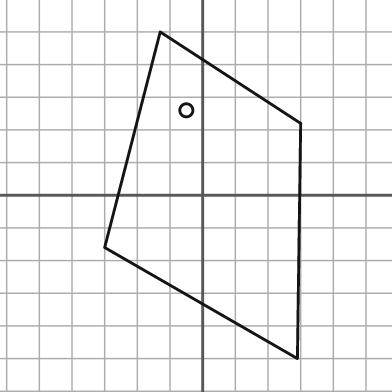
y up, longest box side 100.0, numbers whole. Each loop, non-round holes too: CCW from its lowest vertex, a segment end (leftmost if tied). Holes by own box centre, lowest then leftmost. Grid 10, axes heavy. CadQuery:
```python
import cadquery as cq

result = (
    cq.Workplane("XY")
    .moveTo(29.0, -50.0)
    .lineTo(30.0, 22.0)
    .lineTo(-13.0, 50.0)
    .lineTo(-30.0, -16.0)
    .close()
    .moveTo(-5.0, 26.0)
    .circle(2.0)
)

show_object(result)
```